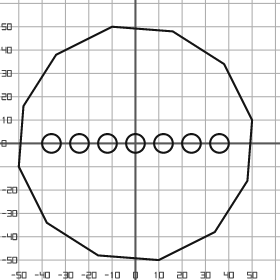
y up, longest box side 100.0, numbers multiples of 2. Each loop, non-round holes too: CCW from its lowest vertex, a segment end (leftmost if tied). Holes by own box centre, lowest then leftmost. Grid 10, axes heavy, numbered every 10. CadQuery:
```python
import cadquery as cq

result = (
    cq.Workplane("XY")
    .moveTo(10.0, -50.0)
    .lineTo(34.0, -38.0)
    .lineTo(48.0, -16.0)
    .lineTo(50.0, 10.0)
    .lineTo(38.0, 34.0)
    .lineTo(16.0, 48.0)
    .lineTo(-10.0, 50.0)
    .lineTo(-34.0, 38.0)
    .lineTo(-48.0, 16.0)
    .lineTo(-50.0, -10.0)
    .lineTo(-38.0, -34.0)
    .lineTo(-16.0, -48.0)
    .close()
    .moveTo(-36.0, 0.0)
    .circle(4.0)
    .moveTo(-24.0, 0.0)
    .circle(4.0)
    .moveTo(-12.0, 0.0)
    .circle(4.0)
    .moveTo(0.0, 0.0)
    .circle(4.0)
    .moveTo(12.0, 0.0)
    .circle(4.0)
    .moveTo(24.0, 0.0)
    .circle(4.0)
    .moveTo(36.0, 0.0)
    .circle(4.0)
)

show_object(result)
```